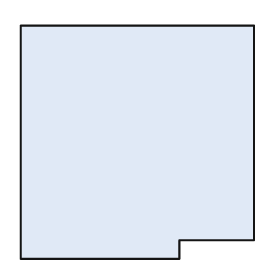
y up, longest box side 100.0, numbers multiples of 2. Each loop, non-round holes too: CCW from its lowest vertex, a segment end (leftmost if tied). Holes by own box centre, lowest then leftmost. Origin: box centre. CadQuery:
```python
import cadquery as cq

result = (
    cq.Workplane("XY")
    .moveTo(-50.0, -50.0)
    .lineTo(18.0, -50.0)
    .lineTo(18.0, -42.0)
    .lineTo(50.0, -42.0)
    .lineTo(50.0, 50.0)
    .lineTo(-50.0, 50.0)
    .close()
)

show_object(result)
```